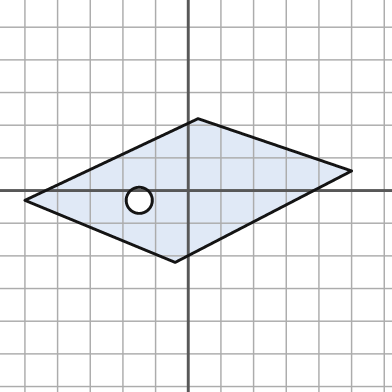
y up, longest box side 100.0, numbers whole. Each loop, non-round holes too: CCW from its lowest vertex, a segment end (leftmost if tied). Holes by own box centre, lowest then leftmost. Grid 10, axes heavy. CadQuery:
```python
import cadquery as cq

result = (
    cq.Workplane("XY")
    .moveTo(-4.0, -22.0)
    .lineTo(50.0, 6.0)
    .lineTo(3.0, 22.0)
    .lineTo(-50.0, -3.0)
    .close()
    .moveTo(-15.0, -3.0)
    .circle(4.0)
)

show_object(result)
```